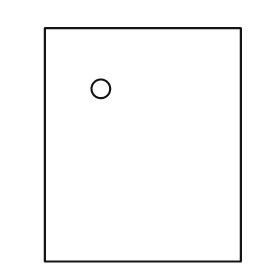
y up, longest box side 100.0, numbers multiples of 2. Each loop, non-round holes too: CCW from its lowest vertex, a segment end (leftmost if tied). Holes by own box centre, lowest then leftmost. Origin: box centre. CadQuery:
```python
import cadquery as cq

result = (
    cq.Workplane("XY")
    .moveTo(-42.0, -50.0)
    .lineTo(42.0, -50.0)
    .lineTo(42.0, 50.0)
    .lineTo(-42.0, 50.0)
    .close()
    .moveTo(-18.0, 24.0)
    .circle(4.0)
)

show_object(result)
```